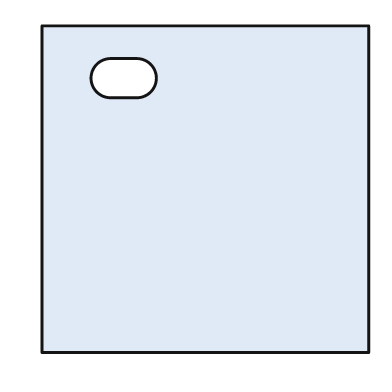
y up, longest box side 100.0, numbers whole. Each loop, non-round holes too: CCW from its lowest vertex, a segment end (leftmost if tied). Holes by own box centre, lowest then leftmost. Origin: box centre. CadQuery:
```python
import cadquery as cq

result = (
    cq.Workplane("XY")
    .moveTo(-50.0, -50.0)
    .lineTo(50.0, -50.0)
    .lineTo(50.0, 50.0)
    .lineTo(-50.0, 50.0)
    .close()
    .moveTo(-29.0, 28.0)
    .lineTo(-21.0, 28.0)
    .threePointArc((-15.0, 34.0), (-21.0, 40.0))
    .lineTo(-29.0, 40.0)
    .threePointArc((-35.0, 34.0), (-29.0, 28.0))
    .close()
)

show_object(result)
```